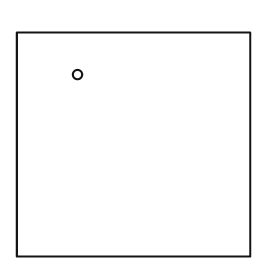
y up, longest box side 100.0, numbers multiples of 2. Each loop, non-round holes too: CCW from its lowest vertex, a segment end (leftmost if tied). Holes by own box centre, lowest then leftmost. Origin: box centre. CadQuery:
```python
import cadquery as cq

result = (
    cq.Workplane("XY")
    .moveTo(-50.0, -48.0)
    .lineTo(50.0, -48.0)
    .lineTo(50.0, 48.0)
    .lineTo(-50.0, 48.0)
    .close()
    .moveTo(-24.0, 30.0)
    .circle(2.0)
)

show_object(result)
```